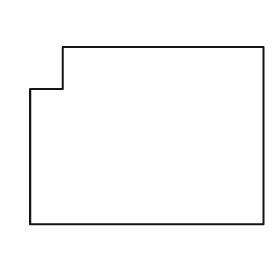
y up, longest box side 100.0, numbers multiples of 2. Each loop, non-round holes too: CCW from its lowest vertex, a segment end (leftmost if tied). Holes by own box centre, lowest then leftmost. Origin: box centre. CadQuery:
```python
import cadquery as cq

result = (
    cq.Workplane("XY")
    .moveTo(-50.0, -38.0)
    .lineTo(50.0, -38.0)
    .lineTo(50.0, 38.0)
    .lineTo(-36.0, 38.0)
    .lineTo(-36.0, 20.0)
    .lineTo(-50.0, 20.0)
    .close()
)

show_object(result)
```